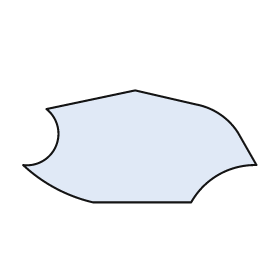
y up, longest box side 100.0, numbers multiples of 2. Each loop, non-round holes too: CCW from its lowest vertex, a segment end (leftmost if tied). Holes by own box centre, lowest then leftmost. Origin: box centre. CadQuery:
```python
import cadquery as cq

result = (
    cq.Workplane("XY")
    .moveTo(-20.0, -24.0)
    .lineTo(22.0, -24.0)
    .threePointArc((34.0, -12.0), (50.0, -8.0))
    .lineTo(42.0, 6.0)
    .threePointArc((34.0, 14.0), (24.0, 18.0))
    .lineTo(-2.0, 24.0)
    .lineTo(-40.0, 16.0)
    .threePointArc((-36.0, 0.0), (-50.0, -8.0))
    .threePointArc((-36.0, -18.0), (-20.0, -24.0))
    .close()
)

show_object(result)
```